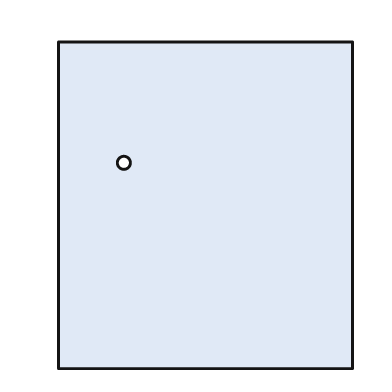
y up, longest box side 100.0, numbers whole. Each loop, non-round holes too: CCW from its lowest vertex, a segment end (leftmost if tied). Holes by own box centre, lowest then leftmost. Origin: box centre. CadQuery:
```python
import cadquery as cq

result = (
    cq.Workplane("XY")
    .moveTo(-45.0, -50.0)
    .lineTo(45.0, -50.0)
    .lineTo(45.0, 50.0)
    .lineTo(-45.0, 50.0)
    .close()
    .moveTo(-25.0, 13.0)
    .circle(2.0)
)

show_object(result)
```